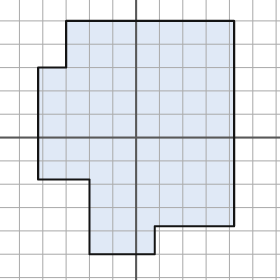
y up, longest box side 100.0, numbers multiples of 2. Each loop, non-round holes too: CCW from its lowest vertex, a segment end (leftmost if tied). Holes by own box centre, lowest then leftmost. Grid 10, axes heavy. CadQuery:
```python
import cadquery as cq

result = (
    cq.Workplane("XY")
    .moveTo(-20.0, -50.0)
    .lineTo(8.0, -50.0)
    .lineTo(8.0, -38.0)
    .lineTo(42.0, -38.0)
    .lineTo(42.0, 50.0)
    .lineTo(-30.0, 50.0)
    .lineTo(-30.0, 30.0)
    .lineTo(-42.0, 30.0)
    .lineTo(-42.0, -18.0)
    .lineTo(-20.0, -18.0)
    .close()
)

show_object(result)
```